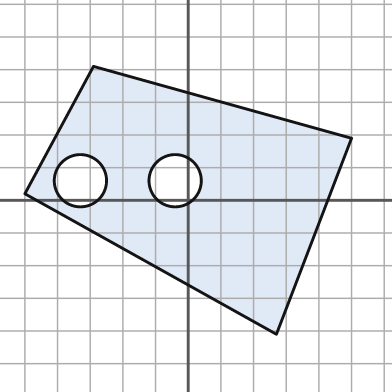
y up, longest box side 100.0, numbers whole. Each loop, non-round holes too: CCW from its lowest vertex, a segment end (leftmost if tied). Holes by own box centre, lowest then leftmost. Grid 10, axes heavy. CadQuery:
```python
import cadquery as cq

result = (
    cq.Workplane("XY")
    .moveTo(27.0, -41.0)
    .lineTo(50.0, 19.0)
    .lineTo(-29.0, 41.0)
    .lineTo(-50.0, 2.0)
    .close()
    .moveTo(-33.0, 6.0)
    .circle(8.0)
    .moveTo(-4.0, 6.0)
    .circle(8.0)
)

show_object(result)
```